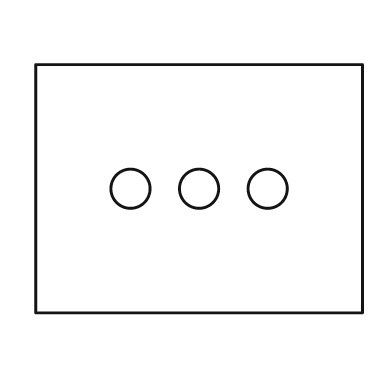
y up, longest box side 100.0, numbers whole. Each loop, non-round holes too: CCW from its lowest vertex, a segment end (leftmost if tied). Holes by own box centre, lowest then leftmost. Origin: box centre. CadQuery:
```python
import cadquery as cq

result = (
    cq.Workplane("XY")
    .moveTo(-50.0, -38.0)
    .lineTo(50.0, -38.0)
    .lineTo(50.0, 38.0)
    .lineTo(-50.0, 38.0)
    .close()
    .moveTo(-21.0, 0.0)
    .circle(6.0)
    .moveTo(0.0, 0.0)
    .circle(6.0)
    .moveTo(21.0, 0.0)
    .circle(6.0)
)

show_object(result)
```